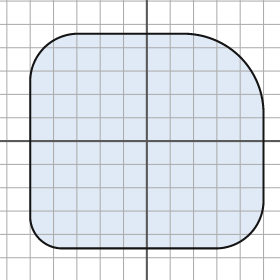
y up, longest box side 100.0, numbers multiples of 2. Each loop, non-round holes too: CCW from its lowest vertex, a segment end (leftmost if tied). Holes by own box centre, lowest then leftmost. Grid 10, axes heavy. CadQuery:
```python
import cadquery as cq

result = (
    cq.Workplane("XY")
    .moveTo(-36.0, -46.0)
    .lineTo(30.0, -46.0)
    .threePointArc((44.0, -40.0), (50.0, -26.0))
    .lineTo(50.0, 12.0)
    .threePointArc((40.0, 36.0), (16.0, 46.0))
    .lineTo(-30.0, 46.0)
    .threePointArc((-44.0, 40.0), (-50.0, 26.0))
    .lineTo(-50.0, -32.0)
    .threePointArc((-46.0, -42.0), (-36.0, -46.0))
    .close()
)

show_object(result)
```